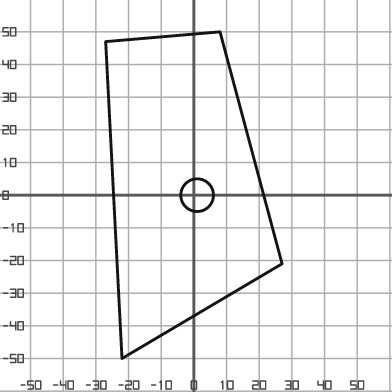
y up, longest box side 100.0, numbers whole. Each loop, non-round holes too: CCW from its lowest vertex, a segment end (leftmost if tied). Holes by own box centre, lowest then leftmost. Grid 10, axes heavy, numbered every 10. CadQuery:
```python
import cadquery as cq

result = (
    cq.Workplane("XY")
    .moveTo(-22.0, -50.0)
    .lineTo(27.0, -21.0)
    .lineTo(8.0, 50.0)
    .lineTo(-27.0, 47.0)
    .close()
    .moveTo(1.0, 0.0)
    .circle(5.0)
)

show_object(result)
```